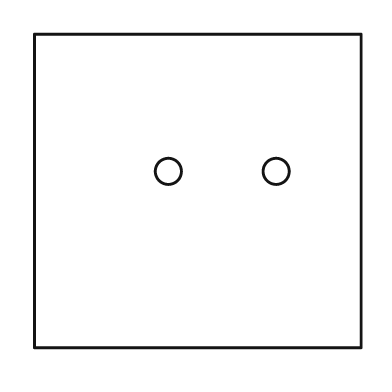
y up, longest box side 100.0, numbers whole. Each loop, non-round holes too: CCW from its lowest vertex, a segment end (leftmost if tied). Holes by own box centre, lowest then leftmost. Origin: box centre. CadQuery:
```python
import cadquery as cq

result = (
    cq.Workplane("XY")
    .moveTo(-50.0, -48.0)
    .lineTo(50.0, -48.0)
    .lineTo(50.0, 48.0)
    .lineTo(-50.0, 48.0)
    .close()
    .moveTo(-9.0, 6.0)
    .circle(4.0)
    .moveTo(24.0, 6.0)
    .circle(4.0)
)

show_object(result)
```